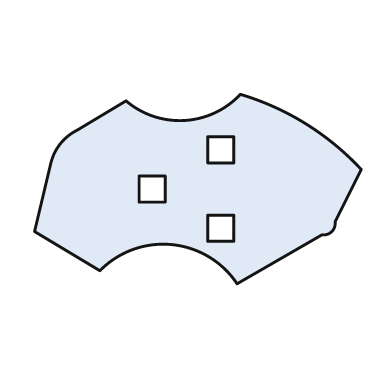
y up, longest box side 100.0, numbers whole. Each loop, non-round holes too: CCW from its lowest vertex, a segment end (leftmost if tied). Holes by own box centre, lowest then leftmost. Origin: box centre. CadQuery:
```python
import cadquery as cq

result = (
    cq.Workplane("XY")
    .moveTo(12.0, -29.0)
    .lineTo(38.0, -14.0)
    .threePointArc((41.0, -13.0), (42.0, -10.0))
    .lineTo(50.0, 6.0)
    .threePointArc((33.0, 20.0), (13.0, 29.0))
    .threePointArc((-4.0, 21.0), (-22.0, 27.0))
    .lineTo(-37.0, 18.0)
    .threePointArc((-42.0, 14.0), (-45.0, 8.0))
    .lineTo(-50.0, -13.0)
    .lineTo(-30.0, -25.0)
    .threePointArc((-8.0, -17.0), (12.0, -29.0))
    .close()
    .moveTo(3.0, -16.0)
    .lineTo(11.0, -16.0)
    .lineTo(11.0, -8.0)
    .lineTo(3.0, -8.0)
    .close()
    .moveTo(-18.0, -4.0)
    .lineTo(-10.0, -4.0)
    .lineTo(-10.0, 4.0)
    .lineTo(-18.0, 4.0)
    .close()
    .moveTo(3.0, 8.0)
    .lineTo(11.0, 8.0)
    .lineTo(11.0, 16.0)
    .lineTo(3.0, 16.0)
    .close()
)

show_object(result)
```